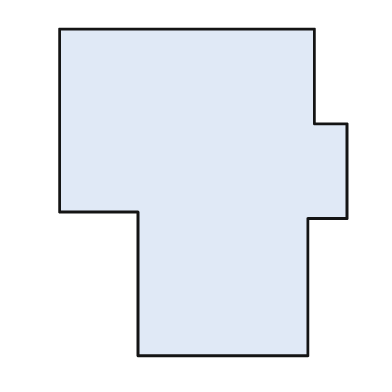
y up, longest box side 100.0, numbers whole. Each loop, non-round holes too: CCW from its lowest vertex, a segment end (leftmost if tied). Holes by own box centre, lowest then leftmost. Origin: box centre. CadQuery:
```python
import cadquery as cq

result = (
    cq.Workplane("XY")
    .moveTo(-20.0, -50.0)
    .lineTo(32.0, -50.0)
    .lineTo(32.0, -8.0)
    .lineTo(44.0, -8.0)
    .lineTo(44.0, 21.0)
    .lineTo(34.0, 21.0)
    .lineTo(34.0, 50.0)
    .lineTo(-44.0, 50.0)
    .lineTo(-44.0, -6.0)
    .lineTo(-20.0, -6.0)
    .close()
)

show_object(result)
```